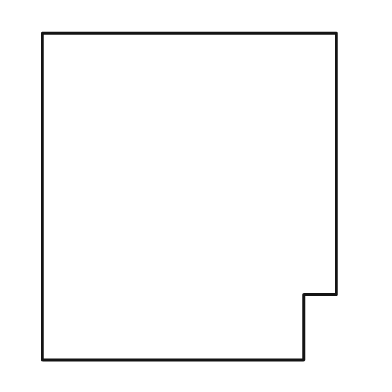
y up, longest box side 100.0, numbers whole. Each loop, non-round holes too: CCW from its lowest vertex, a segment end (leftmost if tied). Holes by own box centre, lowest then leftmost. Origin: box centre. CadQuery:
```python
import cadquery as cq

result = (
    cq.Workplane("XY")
    .moveTo(-45.0, -50.0)
    .lineTo(35.0, -50.0)
    .lineTo(35.0, -30.0)
    .lineTo(45.0, -30.0)
    .lineTo(45.0, 50.0)
    .lineTo(-45.0, 50.0)
    .close()
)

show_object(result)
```